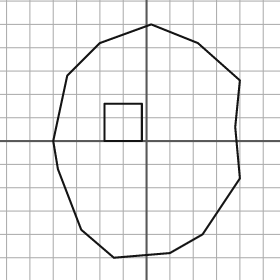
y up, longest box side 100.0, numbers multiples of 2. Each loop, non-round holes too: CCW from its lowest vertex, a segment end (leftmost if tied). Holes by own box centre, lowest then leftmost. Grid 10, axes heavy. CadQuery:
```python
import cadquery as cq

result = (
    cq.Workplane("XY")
    .moveTo(-14.0, -50.0)
    .lineTo(10.0, -48.0)
    .lineTo(24.0, -40.0)
    .lineTo(40.0, -16.0)
    .lineTo(38.0, 6.0)
    .lineTo(40.0, 26.0)
    .lineTo(22.0, 42.0)
    .lineTo(2.0, 50.0)
    .lineTo(-20.0, 42.0)
    .lineTo(-34.0, 28.0)
    .lineTo(-40.0, 0.0)
    .lineTo(-38.0, -12.0)
    .lineTo(-28.0, -38.0)
    .close()
    .moveTo(-18.0, 0.0)
    .lineTo(-2.0, 0.0)
    .lineTo(-2.0, 16.0)
    .lineTo(-18.0, 16.0)
    .close()
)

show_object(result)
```